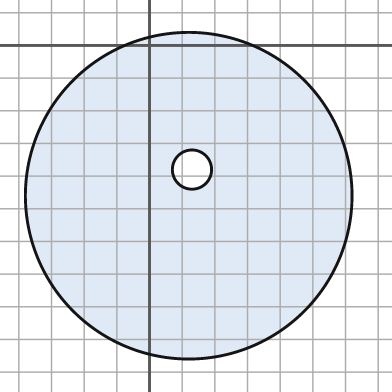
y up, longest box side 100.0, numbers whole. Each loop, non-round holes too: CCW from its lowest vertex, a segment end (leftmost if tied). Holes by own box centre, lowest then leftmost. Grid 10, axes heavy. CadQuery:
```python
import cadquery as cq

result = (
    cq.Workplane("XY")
    .moveTo(12.0, -46.0)
    .circle(50.0)
    .moveTo(13.0, -38.0)
    .circle(6.0)
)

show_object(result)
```